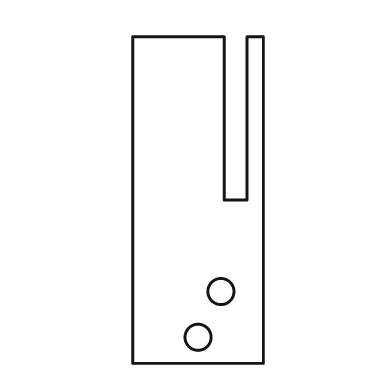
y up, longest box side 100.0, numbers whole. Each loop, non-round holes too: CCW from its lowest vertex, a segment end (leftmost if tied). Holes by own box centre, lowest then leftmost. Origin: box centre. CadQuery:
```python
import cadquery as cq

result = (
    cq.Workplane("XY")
    .moveTo(-20.0, -50.0)
    .lineTo(20.0, -50.0)
    .lineTo(20.0, 50.0)
    .lineTo(15.0, 50.0)
    .lineTo(15.0, 0.0)
    .lineTo(8.0, 0.0)
    .lineTo(8.0, 50.0)
    .lineTo(-20.0, 50.0)
    .close()
    .moveTo(0.0, -42.0)
    .circle(4.0)
    .moveTo(7.0, -28.0)
    .circle(4.0)
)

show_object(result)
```